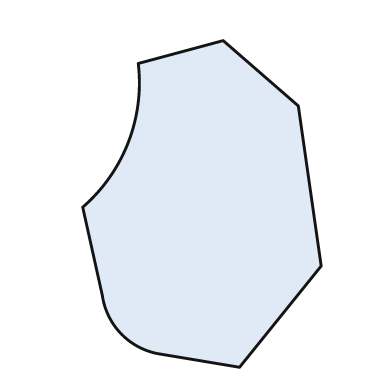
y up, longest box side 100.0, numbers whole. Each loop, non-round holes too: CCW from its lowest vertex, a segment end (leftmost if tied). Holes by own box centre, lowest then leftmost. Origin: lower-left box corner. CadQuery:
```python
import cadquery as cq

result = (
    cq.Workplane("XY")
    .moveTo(48.0, 0.0)
    .lineTo(73.0, 31.0)
    .lineTo(66.0, 80.0)
    .lineTo(43.0, 100.0)
    .lineTo(17.0, 93.0)
    .threePointArc((14.0, 69.0), (0.0, 49.0))
    .lineTo(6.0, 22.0)
    .threePointArc((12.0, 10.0), (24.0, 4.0))
    .close()
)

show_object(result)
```